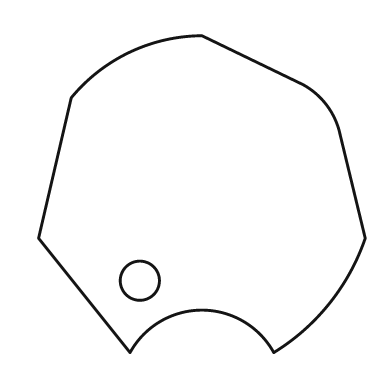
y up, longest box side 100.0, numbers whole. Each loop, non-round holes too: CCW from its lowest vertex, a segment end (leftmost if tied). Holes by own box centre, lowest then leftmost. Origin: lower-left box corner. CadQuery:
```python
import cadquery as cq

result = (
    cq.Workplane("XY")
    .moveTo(28.0, 0.0)
    .threePointArc((50.0, 13.0), (72.0, 0.0))
    .threePointArc((89.0, 15.0), (100.0, 35.0))
    .lineTo(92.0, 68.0)
    .threePointArc((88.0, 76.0), (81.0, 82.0))
    .lineTo(50.0, 97.0)
    .threePointArc((28.0, 92.0), (10.0, 78.0))
    .lineTo(0.0, 35.0)
    .close()
    .moveTo(31.0, 22.0)
    .circle(6.0)
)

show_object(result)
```